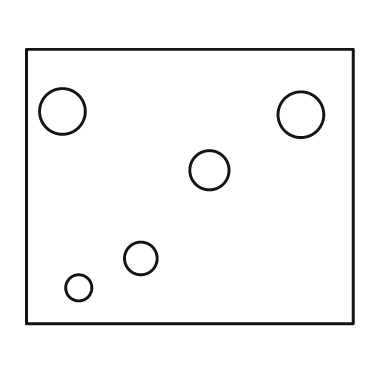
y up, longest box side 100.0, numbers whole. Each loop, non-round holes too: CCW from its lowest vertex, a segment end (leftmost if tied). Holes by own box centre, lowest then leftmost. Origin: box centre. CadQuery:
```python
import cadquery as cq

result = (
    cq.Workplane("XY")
    .moveTo(-50.0, -42.0)
    .lineTo(50.0, -42.0)
    .lineTo(50.0, 42.0)
    .lineTo(-50.0, 42.0)
    .close()
    .moveTo(-34.0, -31.0)
    .circle(4.0)
    .moveTo(-15.0, -22.0)
    .circle(5.0)
    .moveTo(6.0, 5.0)
    .circle(6.0)
    .moveTo(34.0, 22.0)
    .circle(7.0)
    .moveTo(-39.0, 23.0)
    .circle(7.0)
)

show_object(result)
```